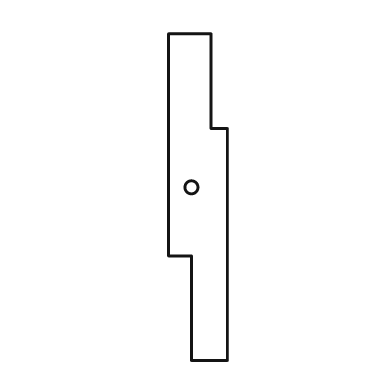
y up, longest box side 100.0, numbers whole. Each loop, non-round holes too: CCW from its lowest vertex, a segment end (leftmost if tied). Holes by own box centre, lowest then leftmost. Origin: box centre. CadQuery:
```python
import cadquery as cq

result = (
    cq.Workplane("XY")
    .moveTo(-2.0, -50.0)
    .lineTo(9.0, -50.0)
    .lineTo(9.0, 21.0)
    .lineTo(4.0, 21.0)
    .lineTo(4.0, 50.0)
    .lineTo(-9.0, 50.0)
    .lineTo(-9.0, -18.0)
    .lineTo(-2.0, -18.0)
    .close()
    .moveTo(-2.0, 3.0)
    .circle(2.0)
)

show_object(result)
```